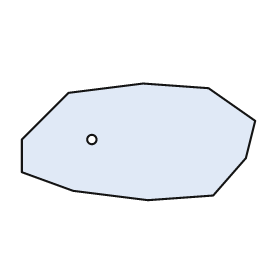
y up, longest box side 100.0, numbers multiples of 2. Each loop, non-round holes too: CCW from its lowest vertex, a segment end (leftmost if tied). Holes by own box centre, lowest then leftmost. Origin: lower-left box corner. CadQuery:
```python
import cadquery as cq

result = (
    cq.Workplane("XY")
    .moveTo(54.0, 0.0)
    .lineTo(82.0, 2.0)
    .lineTo(96.0, 18.0)
    .lineTo(100.0, 34.0)
    .lineTo(80.0, 48.0)
    .lineTo(52.0, 50.0)
    .lineTo(20.0, 46.0)
    .lineTo(0.0, 26.0)
    .lineTo(0.0, 12.0)
    .lineTo(22.0, 4.0)
    .close()
    .moveTo(30.0, 26.0)
    .circle(2.0)
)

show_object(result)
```